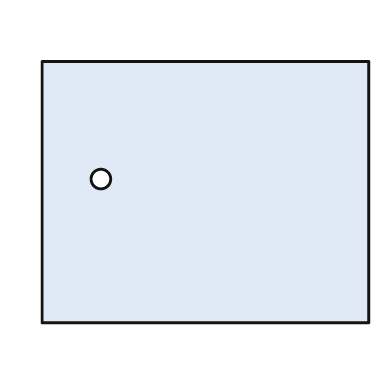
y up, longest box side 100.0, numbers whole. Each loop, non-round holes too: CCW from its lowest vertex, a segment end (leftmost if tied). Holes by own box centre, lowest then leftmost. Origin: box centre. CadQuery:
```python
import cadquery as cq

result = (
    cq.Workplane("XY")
    .moveTo(-50.0, -40.0)
    .lineTo(50.0, -40.0)
    .lineTo(50.0, 40.0)
    .lineTo(-50.0, 40.0)
    .close()
    .moveTo(-32.0, 4.0)
    .circle(3.0)
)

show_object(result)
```